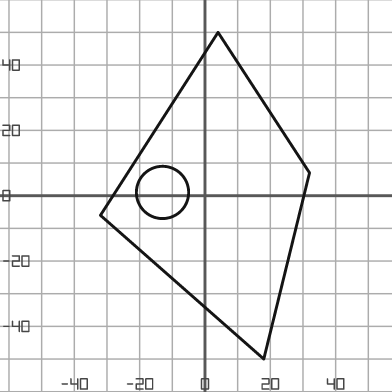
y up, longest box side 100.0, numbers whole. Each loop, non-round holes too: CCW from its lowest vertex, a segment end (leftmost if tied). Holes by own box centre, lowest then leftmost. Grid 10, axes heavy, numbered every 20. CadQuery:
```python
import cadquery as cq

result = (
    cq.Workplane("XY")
    .moveTo(18.0, -50.0)
    .lineTo(32.0, 7.0)
    .lineTo(4.0, 50.0)
    .lineTo(-32.0, -6.0)
    .close()
    .moveTo(-13.0, 1.0)
    .circle(8.0)
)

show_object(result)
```